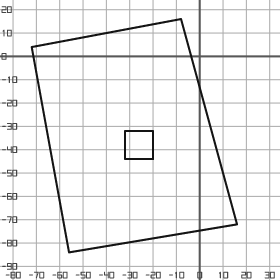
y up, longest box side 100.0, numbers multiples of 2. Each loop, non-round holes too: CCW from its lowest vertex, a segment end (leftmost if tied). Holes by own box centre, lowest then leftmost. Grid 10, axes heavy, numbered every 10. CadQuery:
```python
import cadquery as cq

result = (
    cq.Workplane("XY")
    .moveTo(-56.0, -84.0)
    .lineTo(16.0, -72.0)
    .lineTo(-8.0, 16.0)
    .lineTo(-72.0, 4.0)
    .close()
    .moveTo(-32.0, -44.0)
    .lineTo(-20.0, -44.0)
    .lineTo(-20.0, -32.0)
    .lineTo(-32.0, -32.0)
    .close()
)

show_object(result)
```